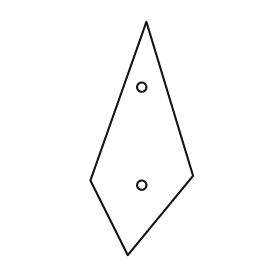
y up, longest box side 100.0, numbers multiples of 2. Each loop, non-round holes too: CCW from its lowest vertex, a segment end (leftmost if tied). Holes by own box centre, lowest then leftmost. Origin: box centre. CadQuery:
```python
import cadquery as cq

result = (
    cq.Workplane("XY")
    .moveTo(-6.0, -50.0)
    .lineTo(22.0, -16.0)
    .lineTo(2.0, 50.0)
    .lineTo(-22.0, -18.0)
    .close()
    .moveTo(0.0, -20.0)
    .circle(2.0)
    .moveTo(0.0, 22.0)
    .circle(2.0)
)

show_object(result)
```